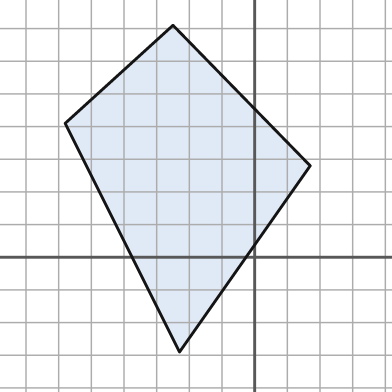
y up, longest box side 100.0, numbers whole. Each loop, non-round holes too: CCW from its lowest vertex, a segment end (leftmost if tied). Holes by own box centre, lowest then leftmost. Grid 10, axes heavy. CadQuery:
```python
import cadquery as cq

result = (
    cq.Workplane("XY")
    .moveTo(-23.0, -29.0)
    .lineTo(17.0, 28.0)
    .lineTo(-25.0, 71.0)
    .lineTo(-58.0, 41.0)
    .close()
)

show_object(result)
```